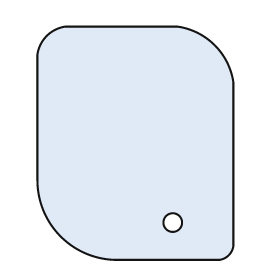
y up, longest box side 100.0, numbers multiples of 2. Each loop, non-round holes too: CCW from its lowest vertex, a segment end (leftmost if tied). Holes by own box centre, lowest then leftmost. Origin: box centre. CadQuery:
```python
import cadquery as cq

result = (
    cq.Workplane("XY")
    .moveTo(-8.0, -50.0)
    .lineTo(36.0, -50.0)
    .threePointArc((40.0, -48.0), (42.0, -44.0))
    .lineTo(42.0, 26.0)
    .threePointArc((34.0, 42.0), (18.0, 50.0))
    .lineTo(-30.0, 50.0)
    .threePointArc((-38.0, 46.0), (-42.0, 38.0))
    .lineTo(-42.0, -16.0)
    .threePointArc((-32.0, -40.0), (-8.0, -50.0))
    .close()
    .moveTo(16.0, -34.0)
    .circle(4.0)
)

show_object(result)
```